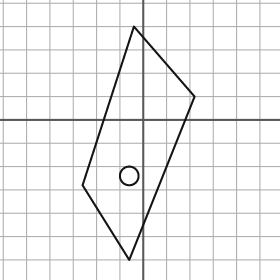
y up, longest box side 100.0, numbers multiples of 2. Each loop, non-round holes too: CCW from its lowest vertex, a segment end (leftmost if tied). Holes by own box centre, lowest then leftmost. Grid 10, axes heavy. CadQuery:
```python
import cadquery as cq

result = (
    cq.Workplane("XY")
    .moveTo(-6.0, -60.0)
    .lineTo(22.0, 10.0)
    .lineTo(-4.0, 40.0)
    .lineTo(-26.0, -28.0)
    .close()
    .moveTo(-6.0, -24.0)
    .circle(4.0)
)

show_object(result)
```